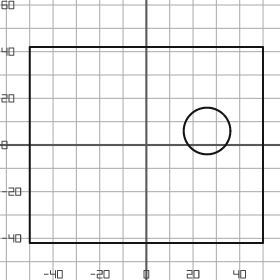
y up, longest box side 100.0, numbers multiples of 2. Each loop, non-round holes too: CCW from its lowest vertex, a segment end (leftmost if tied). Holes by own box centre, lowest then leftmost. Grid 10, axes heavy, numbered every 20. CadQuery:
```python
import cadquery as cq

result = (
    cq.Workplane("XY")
    .moveTo(-50.0, -42.0)
    .lineTo(50.0, -42.0)
    .lineTo(50.0, 42.0)
    .lineTo(-50.0, 42.0)
    .close()
    .moveTo(26.0, 6.0)
    .circle(10.0)
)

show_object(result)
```